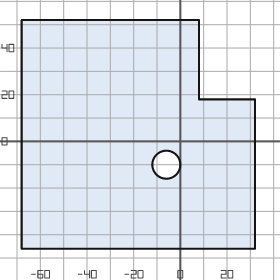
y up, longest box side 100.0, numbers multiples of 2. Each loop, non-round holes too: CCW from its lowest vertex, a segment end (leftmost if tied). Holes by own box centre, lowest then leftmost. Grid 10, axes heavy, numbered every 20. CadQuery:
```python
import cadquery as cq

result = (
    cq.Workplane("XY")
    .moveTo(-68.0, -46.0)
    .lineTo(32.0, -46.0)
    .lineTo(32.0, 18.0)
    .lineTo(8.0, 18.0)
    .lineTo(8.0, 52.0)
    .lineTo(-68.0, 52.0)
    .close()
    .moveTo(-6.0, -10.0)
    .circle(6.0)
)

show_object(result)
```